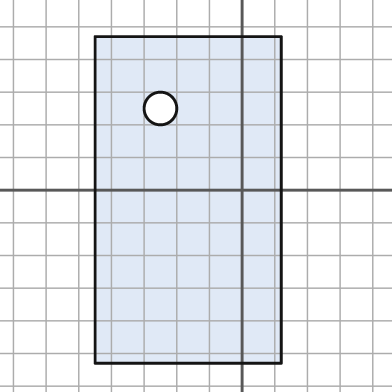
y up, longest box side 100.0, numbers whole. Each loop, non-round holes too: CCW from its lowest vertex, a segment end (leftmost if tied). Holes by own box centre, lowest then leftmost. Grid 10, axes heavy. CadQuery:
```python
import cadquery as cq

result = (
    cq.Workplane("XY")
    .moveTo(-45.0, -53.0)
    .lineTo(12.0, -53.0)
    .lineTo(12.0, 47.0)
    .lineTo(-45.0, 47.0)
    .close()
    .moveTo(-25.0, 25.0)
    .circle(5.0)
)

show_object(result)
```